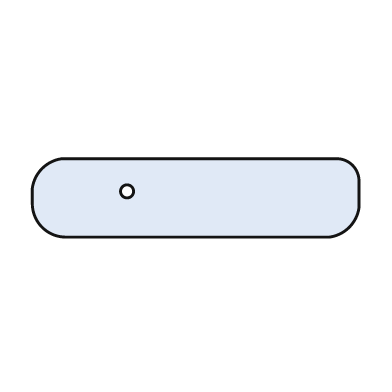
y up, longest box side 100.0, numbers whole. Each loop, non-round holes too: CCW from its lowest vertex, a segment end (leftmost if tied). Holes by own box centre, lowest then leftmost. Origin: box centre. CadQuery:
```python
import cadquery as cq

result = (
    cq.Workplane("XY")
    .moveTo(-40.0, -12.0)
    .lineTo(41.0, -12.0)
    .threePointArc((47.0, -9.0), (50.0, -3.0))
    .lineTo(50.0, 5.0)
    .threePointArc((48.0, 10.0), (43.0, 12.0))
    .lineTo(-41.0, 12.0)
    .threePointArc((-47.0, 9.0), (-50.0, 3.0))
    .lineTo(-50.0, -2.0)
    .threePointArc((-47.0, -9.0), (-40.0, -12.0))
    .close()
    .moveTo(-21.0, 2.0)
    .circle(2.0)
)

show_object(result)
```